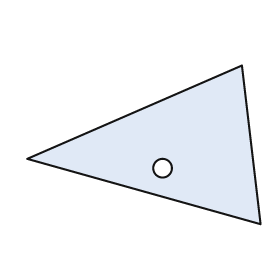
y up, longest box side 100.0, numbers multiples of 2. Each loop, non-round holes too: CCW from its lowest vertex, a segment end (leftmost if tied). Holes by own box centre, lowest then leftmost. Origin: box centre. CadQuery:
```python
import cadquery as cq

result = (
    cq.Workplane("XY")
    .moveTo(50.0, -34.0)
    .lineTo(42.0, 34.0)
    .lineTo(-50.0, -6.0)
    .close()
    .moveTo(8.0, -10.0)
    .circle(4.0)
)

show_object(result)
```